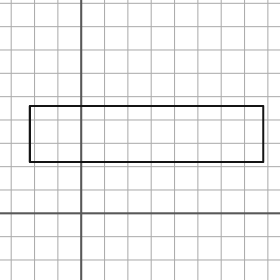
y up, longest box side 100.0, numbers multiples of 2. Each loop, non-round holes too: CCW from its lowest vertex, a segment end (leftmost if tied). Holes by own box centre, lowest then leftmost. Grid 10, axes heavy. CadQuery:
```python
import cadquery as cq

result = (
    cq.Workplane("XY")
    .moveTo(-22.0, 22.0)
    .lineTo(78.0, 22.0)
    .lineTo(78.0, 46.0)
    .lineTo(-22.0, 46.0)
    .close()
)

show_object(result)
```